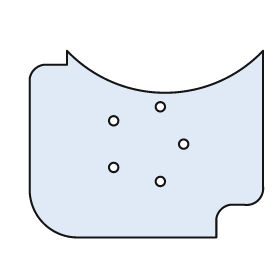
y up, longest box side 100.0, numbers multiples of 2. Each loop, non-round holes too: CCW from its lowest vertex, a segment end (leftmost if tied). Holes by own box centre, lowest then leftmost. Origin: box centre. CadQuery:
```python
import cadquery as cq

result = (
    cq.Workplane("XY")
    .moveTo(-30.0, -40.0)
    .lineTo(30.0, -40.0)
    .lineTo(30.0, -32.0)
    .threePointArc((32.0, -28.0), (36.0, -26.0))
    .lineTo(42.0, -26.0)
    .threePointArc((48.0, -24.0), (50.0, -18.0))
    .lineTo(50.0, 40.0)
    .threePointArc((8.0, 22.0), (-34.0, 40.0))
    .lineTo(-34.0, 34.0)
    .lineTo(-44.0, 34.0)
    .threePointArc((-48.0, 32.0), (-50.0, 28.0))
    .lineTo(-50.0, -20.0)
    .threePointArc((-44.0, -34.0), (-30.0, -40.0))
    .close()
    .moveTo(6.0, -16.0)
    .circle(2.0)
    .moveTo(-14.0, -10.0)
    .circle(2.0)
    .moveTo(16.0, 0.0)
    .circle(2.0)
    .moveTo(-14.0, 10.0)
    .circle(2.0)
    .moveTo(6.0, 16.0)
    .circle(2.0)
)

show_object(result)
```